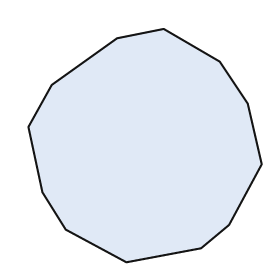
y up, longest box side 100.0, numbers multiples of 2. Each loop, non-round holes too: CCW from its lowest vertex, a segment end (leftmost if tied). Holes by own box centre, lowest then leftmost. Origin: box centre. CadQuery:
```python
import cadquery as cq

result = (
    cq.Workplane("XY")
    .moveTo(-8.0, -50.0)
    .lineTo(24.0, -44.0)
    .lineTo(36.0, -34.0)
    .lineTo(50.0, -8.0)
    .lineTo(44.0, 18.0)
    .lineTo(32.0, 36.0)
    .lineTo(8.0, 50.0)
    .lineTo(-12.0, 46.0)
    .lineTo(-40.0, 26.0)
    .lineTo(-50.0, 8.0)
    .lineTo(-44.0, -20.0)
    .lineTo(-34.0, -36.0)
    .close()
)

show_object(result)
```